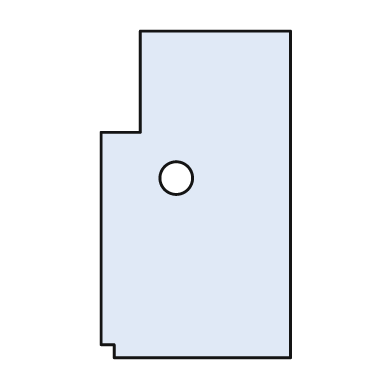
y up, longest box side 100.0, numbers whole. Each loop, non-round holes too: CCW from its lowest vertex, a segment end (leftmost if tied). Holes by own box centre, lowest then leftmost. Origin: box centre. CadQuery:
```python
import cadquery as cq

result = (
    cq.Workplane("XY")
    .moveTo(-25.0, -50.0)
    .lineTo(29.0, -50.0)
    .lineTo(29.0, 50.0)
    .lineTo(-17.0, 50.0)
    .lineTo(-17.0, 19.0)
    .lineTo(-29.0, 19.0)
    .lineTo(-29.0, -46.0)
    .lineTo(-25.0, -46.0)
    .close()
    .moveTo(-6.0, 5.0)
    .circle(5.0)
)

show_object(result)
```